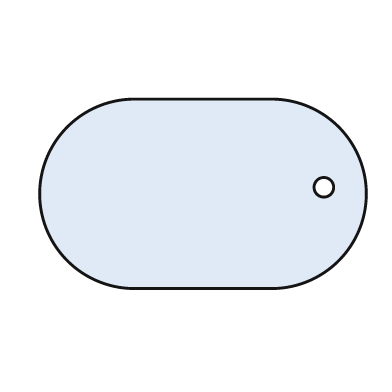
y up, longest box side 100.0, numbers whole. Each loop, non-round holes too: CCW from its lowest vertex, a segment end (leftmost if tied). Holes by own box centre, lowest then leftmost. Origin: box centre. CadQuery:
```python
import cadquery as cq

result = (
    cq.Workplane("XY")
    .moveTo(-21.0, -29.0)
    .lineTo(21.0, -29.0)
    .threePointArc((50.0, 0.0), (21.0, 29.0))
    .lineTo(-21.0, 29.0)
    .threePointArc((-50.0, 0.0), (-21.0, -29.0))
    .close()
    .moveTo(37.0, 2.0)
    .circle(3.0)
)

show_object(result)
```